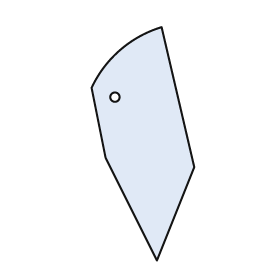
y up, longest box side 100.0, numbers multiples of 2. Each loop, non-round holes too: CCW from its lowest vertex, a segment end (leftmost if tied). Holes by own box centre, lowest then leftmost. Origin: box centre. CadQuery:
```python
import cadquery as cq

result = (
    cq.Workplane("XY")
    .moveTo(6.0, -50.0)
    .lineTo(22.0, -10.0)
    .lineTo(8.0, 50.0)
    .threePointArc((-10.0, 40.0), (-22.0, 24.0))
    .lineTo(-16.0, -6.0)
    .close()
    .moveTo(-12.0, 20.0)
    .circle(2.0)
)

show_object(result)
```